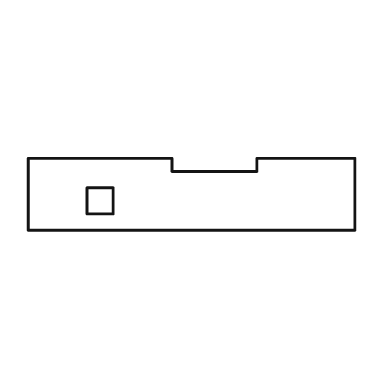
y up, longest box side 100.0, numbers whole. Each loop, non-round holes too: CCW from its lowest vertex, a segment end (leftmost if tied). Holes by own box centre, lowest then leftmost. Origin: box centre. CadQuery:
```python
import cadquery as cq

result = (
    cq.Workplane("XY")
    .moveTo(-50.0, -11.0)
    .lineTo(50.0, -11.0)
    .lineTo(50.0, 11.0)
    .lineTo(20.0, 11.0)
    .lineTo(20.0, 7.0)
    .lineTo(-6.0, 7.0)
    .lineTo(-6.0, 11.0)
    .lineTo(-50.0, 11.0)
    .close()
    .moveTo(-32.0, -6.0)
    .lineTo(-24.0, -6.0)
    .lineTo(-24.0, 2.0)
    .lineTo(-32.0, 2.0)
    .close()
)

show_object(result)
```